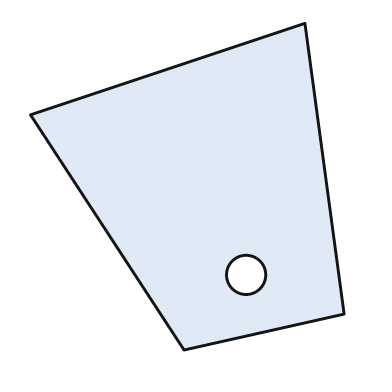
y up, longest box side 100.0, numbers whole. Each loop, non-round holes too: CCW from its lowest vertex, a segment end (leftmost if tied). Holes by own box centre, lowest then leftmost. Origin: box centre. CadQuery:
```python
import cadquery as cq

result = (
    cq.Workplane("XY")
    .moveTo(-1.0, -50.0)
    .lineTo(48.0, -39.0)
    .lineTo(36.0, 50.0)
    .lineTo(-48.0, 22.0)
    .close()
    .moveTo(18.0, -27.0)
    .circle(6.0)
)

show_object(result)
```